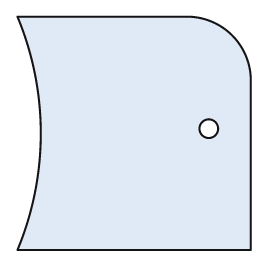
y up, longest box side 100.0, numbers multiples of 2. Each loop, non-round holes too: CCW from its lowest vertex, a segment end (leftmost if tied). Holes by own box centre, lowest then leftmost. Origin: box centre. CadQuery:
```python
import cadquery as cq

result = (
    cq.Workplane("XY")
    .moveTo(-50.0, -50.0)
    .lineTo(50.0, -50.0)
    .lineTo(50.0, 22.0)
    .threePointArc((42.0, 42.0), (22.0, 50.0))
    .lineTo(-50.0, 50.0)
    .threePointArc((-40.0, 0.0), (-50.0, -50.0))
    .close()
    .moveTo(32.0, 2.0)
    .circle(4.0)
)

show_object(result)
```